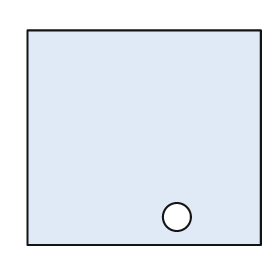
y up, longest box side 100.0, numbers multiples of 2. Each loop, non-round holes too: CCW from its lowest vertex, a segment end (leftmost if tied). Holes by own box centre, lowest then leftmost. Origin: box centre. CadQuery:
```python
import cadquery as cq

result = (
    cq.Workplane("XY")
    .moveTo(-50.0, -46.0)
    .lineTo(50.0, -46.0)
    .lineTo(50.0, 46.0)
    .lineTo(-50.0, 46.0)
    .close()
    .moveTo(14.0, -34.0)
    .circle(6.0)
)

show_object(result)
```